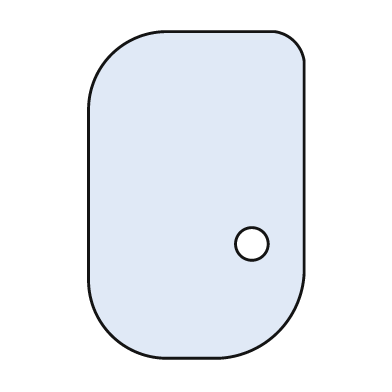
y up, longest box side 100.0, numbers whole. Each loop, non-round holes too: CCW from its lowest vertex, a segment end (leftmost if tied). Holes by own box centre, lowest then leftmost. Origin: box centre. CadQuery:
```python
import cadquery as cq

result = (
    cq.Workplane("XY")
    .moveTo(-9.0, -50.0)
    .lineTo(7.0, -50.0)
    .threePointArc((25.0, -42.0), (33.0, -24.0))
    .lineTo(33.0, 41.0)
    .threePointArc((30.0, 47.0), (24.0, 50.0))
    .lineTo(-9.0, 50.0)
    .threePointArc((-26.0, 43.0), (-33.0, 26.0))
    .lineTo(-33.0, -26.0)
    .threePointArc((-26.0, -43.0), (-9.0, -50.0))
    .close()
    .moveTo(17.0, -15.0)
    .circle(5.0)
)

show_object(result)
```